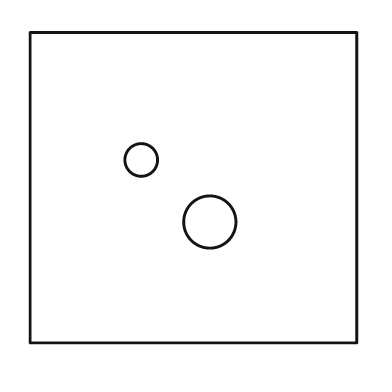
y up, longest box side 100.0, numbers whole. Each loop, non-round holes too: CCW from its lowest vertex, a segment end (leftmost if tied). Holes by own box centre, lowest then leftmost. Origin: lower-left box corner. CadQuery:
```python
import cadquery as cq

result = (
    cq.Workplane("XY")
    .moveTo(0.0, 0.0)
    .lineTo(100.0, 0.0)
    .lineTo(100.0, 95.0)
    .lineTo(0.0, 95.0)
    .close()
    .moveTo(55.0, 37.0)
    .circle(8.0)
    .moveTo(34.0, 56.0)
    .circle(5.0)
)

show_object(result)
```